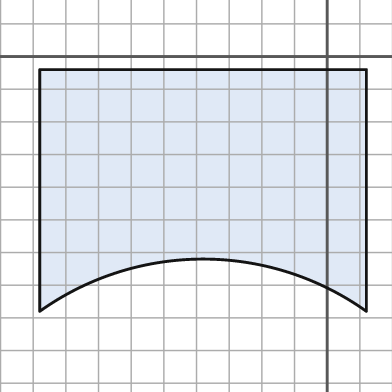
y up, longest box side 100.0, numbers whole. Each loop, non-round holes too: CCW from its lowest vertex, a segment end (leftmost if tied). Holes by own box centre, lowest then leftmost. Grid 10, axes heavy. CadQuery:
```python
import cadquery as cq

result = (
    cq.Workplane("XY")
    .moveTo(-88.0, -78.0)
    .threePointArc((-38.0, -62.0), (12.0, -78.0))
    .lineTo(12.0, -4.0)
    .lineTo(-88.0, -4.0)
    .close()
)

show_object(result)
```